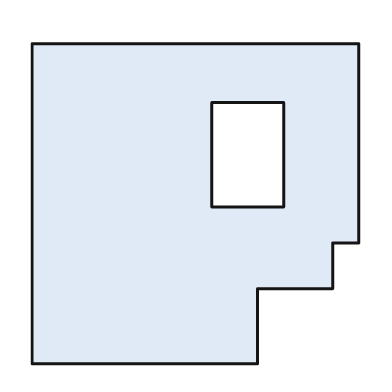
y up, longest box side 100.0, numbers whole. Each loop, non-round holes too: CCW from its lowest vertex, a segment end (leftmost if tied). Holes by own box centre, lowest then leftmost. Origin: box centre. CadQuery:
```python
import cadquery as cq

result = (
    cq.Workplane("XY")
    .moveTo(-50.0, -49.0)
    .lineTo(19.0, -49.0)
    .lineTo(19.0, -26.0)
    .lineTo(42.0, -26.0)
    .lineTo(42.0, -12.0)
    .lineTo(50.0, -12.0)
    .lineTo(50.0, 49.0)
    .lineTo(-50.0, 49.0)
    .close()
    .moveTo(5.0, -1.0)
    .lineTo(27.0, -1.0)
    .lineTo(27.0, 31.0)
    .lineTo(5.0, 31.0)
    .close()
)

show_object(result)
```